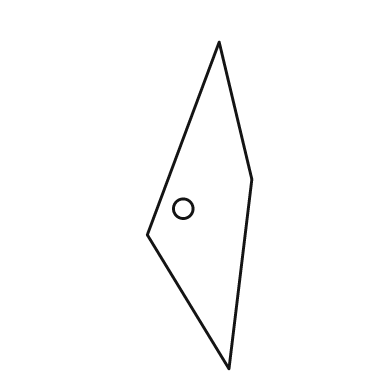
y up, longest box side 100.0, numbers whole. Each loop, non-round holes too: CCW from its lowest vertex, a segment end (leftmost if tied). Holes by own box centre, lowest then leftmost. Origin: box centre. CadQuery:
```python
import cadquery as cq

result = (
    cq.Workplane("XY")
    .moveTo(9.0, -50.0)
    .lineTo(16.0, 8.0)
    .lineTo(6.0, 50.0)
    .lineTo(-16.0, -9.0)
    .close()
    .moveTo(-5.0, -1.0)
    .circle(3.0)
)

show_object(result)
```